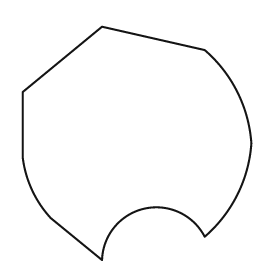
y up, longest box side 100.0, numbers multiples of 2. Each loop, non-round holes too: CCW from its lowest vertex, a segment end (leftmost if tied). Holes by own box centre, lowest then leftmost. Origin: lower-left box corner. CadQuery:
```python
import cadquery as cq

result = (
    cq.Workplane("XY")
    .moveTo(34.0, 0.0)
    .threePointArc((52.0, 22.0), (78.0, 10.0))
    .threePointArc((92.0, 28.0), (98.0, 50.0))
    .threePointArc((92.0, 72.0), (78.0, 90.0))
    .lineTo(34.0, 100.0)
    .lineTo(0.0, 72.0)
    .lineTo(0.0, 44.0)
    .threePointArc((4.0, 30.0), (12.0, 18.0))
    .close()
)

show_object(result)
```